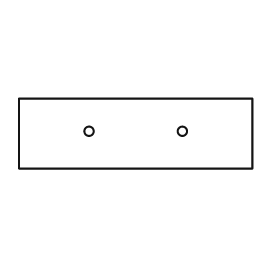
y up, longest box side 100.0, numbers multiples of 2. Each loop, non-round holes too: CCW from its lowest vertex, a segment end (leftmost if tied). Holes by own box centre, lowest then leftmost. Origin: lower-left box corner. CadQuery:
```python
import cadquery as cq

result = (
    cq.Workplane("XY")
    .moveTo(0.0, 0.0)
    .lineTo(100.0, 0.0)
    .lineTo(100.0, 30.0)
    .lineTo(0.0, 30.0)
    .close()
    .moveTo(30.0, 16.0)
    .circle(2.0)
    .moveTo(70.0, 16.0)
    .circle(2.0)
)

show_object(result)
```